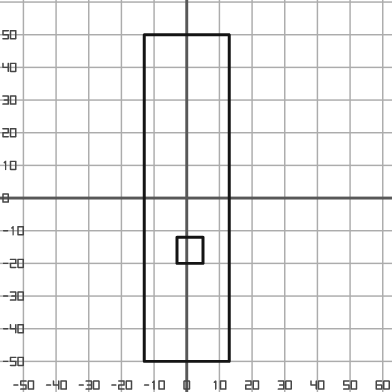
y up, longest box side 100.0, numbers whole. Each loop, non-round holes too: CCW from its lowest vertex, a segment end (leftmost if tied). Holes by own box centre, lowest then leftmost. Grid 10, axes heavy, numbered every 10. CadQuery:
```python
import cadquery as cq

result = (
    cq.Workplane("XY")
    .moveTo(-13.0, -50.0)
    .lineTo(13.0, -50.0)
    .lineTo(13.0, 50.0)
    .lineTo(-13.0, 50.0)
    .close()
    .moveTo(-3.0, -20.0)
    .lineTo(5.0, -20.0)
    .lineTo(5.0, -12.0)
    .lineTo(-3.0, -12.0)
    .close()
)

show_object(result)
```